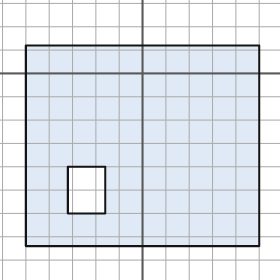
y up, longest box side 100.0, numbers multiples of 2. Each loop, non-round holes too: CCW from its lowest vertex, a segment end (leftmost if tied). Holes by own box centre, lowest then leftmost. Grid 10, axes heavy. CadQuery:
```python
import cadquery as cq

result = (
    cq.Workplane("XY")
    .moveTo(-50.0, -74.0)
    .lineTo(50.0, -74.0)
    .lineTo(50.0, 12.0)
    .lineTo(-50.0, 12.0)
    .close()
    .moveTo(-32.0, -60.0)
    .lineTo(-16.0, -60.0)
    .lineTo(-16.0, -40.0)
    .lineTo(-32.0, -40.0)
    .close()
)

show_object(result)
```